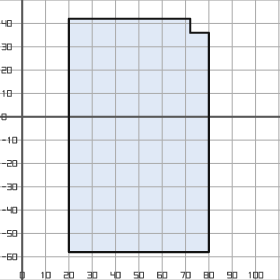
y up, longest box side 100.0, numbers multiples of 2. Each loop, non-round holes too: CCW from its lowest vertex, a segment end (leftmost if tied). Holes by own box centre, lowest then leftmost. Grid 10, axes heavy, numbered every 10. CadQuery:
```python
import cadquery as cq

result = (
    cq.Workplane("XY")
    .moveTo(20.0, -58.0)
    .lineTo(80.0, -58.0)
    .lineTo(80.0, 36.0)
    .lineTo(72.0, 36.0)
    .lineTo(72.0, 42.0)
    .lineTo(20.0, 42.0)
    .close()
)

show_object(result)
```